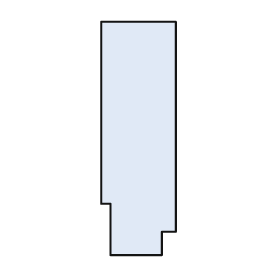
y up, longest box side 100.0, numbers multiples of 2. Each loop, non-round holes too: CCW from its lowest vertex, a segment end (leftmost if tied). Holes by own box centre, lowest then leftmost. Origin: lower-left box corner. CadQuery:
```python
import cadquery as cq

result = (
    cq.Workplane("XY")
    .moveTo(4.0, 0.0)
    .lineTo(26.0, 0.0)
    .lineTo(26.0, 10.0)
    .lineTo(32.0, 10.0)
    .lineTo(32.0, 100.0)
    .lineTo(0.0, 100.0)
    .lineTo(0.0, 22.0)
    .lineTo(4.0, 22.0)
    .close()
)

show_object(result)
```